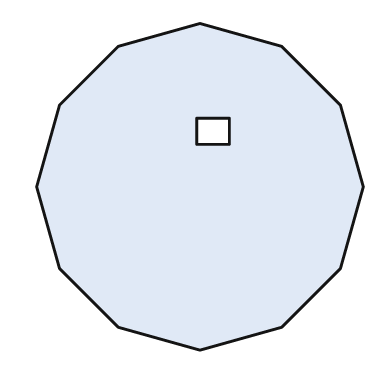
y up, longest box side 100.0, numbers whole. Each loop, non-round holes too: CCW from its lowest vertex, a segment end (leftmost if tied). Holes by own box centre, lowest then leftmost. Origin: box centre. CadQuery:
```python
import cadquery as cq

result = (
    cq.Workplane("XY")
    .moveTo(0.0, -50.0)
    .lineTo(25.0, -43.0)
    .lineTo(43.0, -25.0)
    .lineTo(50.0, 0.0)
    .lineTo(43.0, 25.0)
    .lineTo(25.0, 43.0)
    .lineTo(0.0, 50.0)
    .lineTo(-25.0, 43.0)
    .lineTo(-43.0, 25.0)
    .lineTo(-50.0, 0.0)
    .lineTo(-43.0, -25.0)
    .lineTo(-25.0, -43.0)
    .close()
    .moveTo(-1.0, 13.0)
    .lineTo(9.0, 13.0)
    .lineTo(9.0, 21.0)
    .lineTo(-1.0, 21.0)
    .close()
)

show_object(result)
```